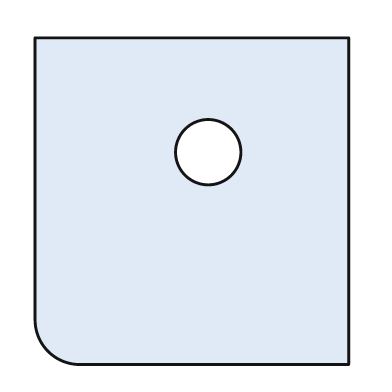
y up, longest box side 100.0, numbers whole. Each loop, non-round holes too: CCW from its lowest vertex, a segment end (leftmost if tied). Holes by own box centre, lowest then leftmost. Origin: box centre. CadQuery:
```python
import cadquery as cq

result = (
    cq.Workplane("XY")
    .moveTo(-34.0, -50.0)
    .lineTo(48.0, -50.0)
    .lineTo(48.0, 50.0)
    .lineTo(-48.0, 50.0)
    .lineTo(-48.0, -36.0)
    .threePointArc((-44.0, -46.0), (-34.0, -50.0))
    .close()
    .moveTo(5.0, 15.0)
    .circle(10.0)
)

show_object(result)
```